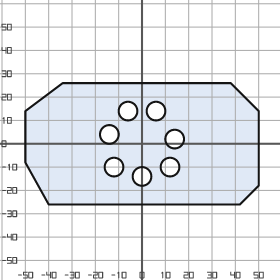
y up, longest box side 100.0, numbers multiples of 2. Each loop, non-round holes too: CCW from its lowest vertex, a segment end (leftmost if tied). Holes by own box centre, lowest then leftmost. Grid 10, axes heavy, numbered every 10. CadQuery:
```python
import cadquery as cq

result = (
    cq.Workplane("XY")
    .moveTo(-40.0, -26.0)
    .lineTo(42.0, -26.0)
    .lineTo(50.0, -18.0)
    .lineTo(50.0, 14.0)
    .lineTo(38.0, 26.0)
    .lineTo(-34.0, 26.0)
    .lineTo(-50.0, 14.0)
    .lineTo(-50.0, -8.0)
    .close()
    .moveTo(0.0, -14.0)
    .circle(4.0)
    .moveTo(-12.0, -10.0)
    .circle(4.0)
    .moveTo(12.0, -10.0)
    .circle(4.0)
    .moveTo(14.0, 2.0)
    .circle(4.0)
    .moveTo(-14.0, 4.0)
    .circle(4.0)
    .moveTo(-6.0, 14.0)
    .circle(4.0)
    .moveTo(6.0, 14.0)
    .circle(4.0)
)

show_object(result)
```